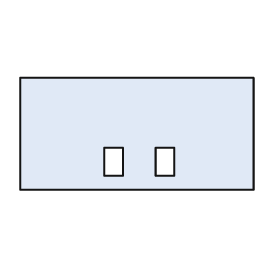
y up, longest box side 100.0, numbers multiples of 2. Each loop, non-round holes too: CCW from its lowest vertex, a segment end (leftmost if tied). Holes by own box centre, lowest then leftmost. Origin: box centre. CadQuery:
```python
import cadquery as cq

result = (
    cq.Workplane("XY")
    .moveTo(-50.0, -24.0)
    .lineTo(50.0, -24.0)
    .lineTo(50.0, 24.0)
    .lineTo(-50.0, 24.0)
    .close()
    .moveTo(-14.0, -18.0)
    .lineTo(-6.0, -18.0)
    .lineTo(-6.0, -6.0)
    .lineTo(-14.0, -6.0)
    .close()
    .moveTo(8.0, -18.0)
    .lineTo(16.0, -18.0)
    .lineTo(16.0, -6.0)
    .lineTo(8.0, -6.0)
    .close()
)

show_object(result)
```